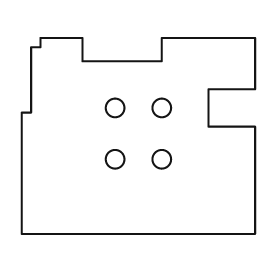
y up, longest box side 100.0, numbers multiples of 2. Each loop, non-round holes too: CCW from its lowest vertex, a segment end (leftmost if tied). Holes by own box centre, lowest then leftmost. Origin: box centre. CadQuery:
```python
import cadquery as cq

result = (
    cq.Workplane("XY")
    .moveTo(-50.0, -42.0)
    .lineTo(50.0, -42.0)
    .lineTo(50.0, 4.0)
    .lineTo(30.0, 4.0)
    .lineTo(30.0, 20.0)
    .lineTo(50.0, 20.0)
    .lineTo(50.0, 42.0)
    .lineTo(10.0, 42.0)
    .lineTo(10.0, 32.0)
    .lineTo(-24.0, 32.0)
    .lineTo(-24.0, 42.0)
    .lineTo(-42.0, 42.0)
    .lineTo(-42.0, 38.0)
    .lineTo(-46.0, 38.0)
    .lineTo(-46.0, 10.0)
    .lineTo(-50.0, 10.0)
    .close()
    .moveTo(-10.0, -10.0)
    .circle(4.0)
    .moveTo(10.0, -10.0)
    .circle(4.0)
    .moveTo(-10.0, 12.0)
    .circle(4.0)
    .moveTo(10.0, 12.0)
    .circle(4.0)
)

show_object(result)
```